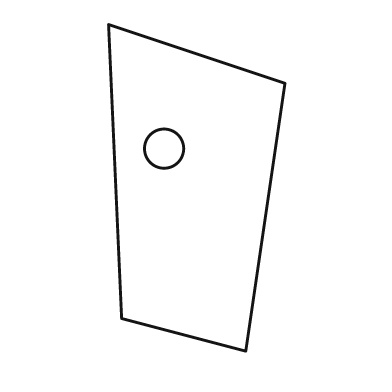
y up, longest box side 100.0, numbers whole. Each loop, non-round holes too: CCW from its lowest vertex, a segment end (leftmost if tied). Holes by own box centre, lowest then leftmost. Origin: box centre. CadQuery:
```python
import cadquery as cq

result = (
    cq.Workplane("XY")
    .moveTo(15.0, -50.0)
    .lineTo(27.0, 32.0)
    .lineTo(-27.0, 50.0)
    .lineTo(-23.0, -40.0)
    .close()
    .moveTo(-10.0, 12.0)
    .circle(6.0)
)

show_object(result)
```